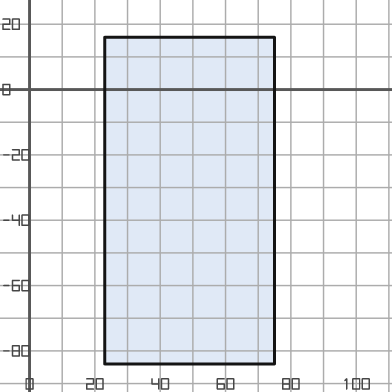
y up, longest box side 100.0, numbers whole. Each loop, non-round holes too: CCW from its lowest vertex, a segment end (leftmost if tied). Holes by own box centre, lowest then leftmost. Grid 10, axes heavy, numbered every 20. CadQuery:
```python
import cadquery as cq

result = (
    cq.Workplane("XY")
    .moveTo(23.0, -84.0)
    .lineTo(75.0, -84.0)
    .lineTo(75.0, 16.0)
    .lineTo(23.0, 16.0)
    .close()
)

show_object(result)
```